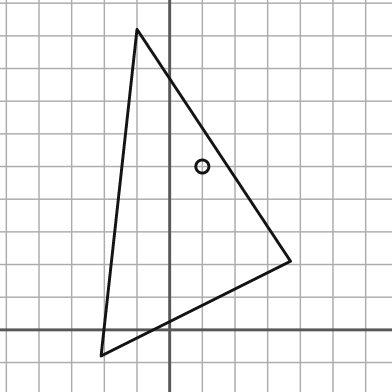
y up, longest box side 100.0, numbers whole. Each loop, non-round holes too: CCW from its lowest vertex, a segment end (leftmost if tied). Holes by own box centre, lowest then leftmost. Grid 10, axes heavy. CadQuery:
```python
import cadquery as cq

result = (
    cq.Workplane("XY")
    .moveTo(-21.0, -8.0)
    .lineTo(37.0, 21.0)
    .lineTo(-10.0, 92.0)
    .close()
    .moveTo(10.0, 50.0)
    .circle(2.0)
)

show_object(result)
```